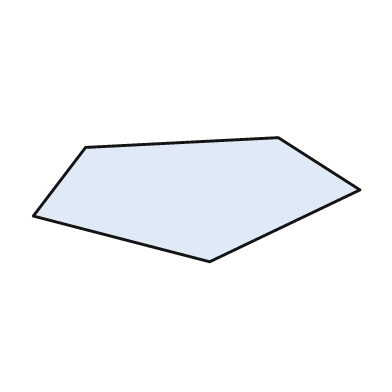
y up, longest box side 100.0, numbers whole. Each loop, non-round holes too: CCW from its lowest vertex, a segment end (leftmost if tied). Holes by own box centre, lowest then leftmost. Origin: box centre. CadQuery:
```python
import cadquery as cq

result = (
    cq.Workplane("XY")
    .moveTo(4.0, -19.0)
    .lineTo(50.0, 3.0)
    .lineTo(25.0, 19.0)
    .lineTo(-34.0, 16.0)
    .lineTo(-50.0, -5.0)
    .close()
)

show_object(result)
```